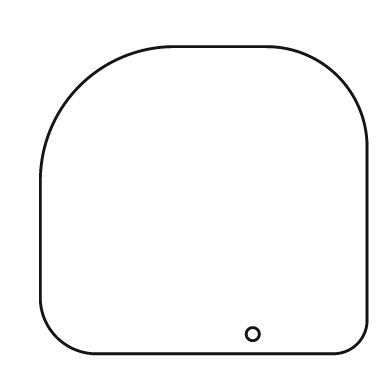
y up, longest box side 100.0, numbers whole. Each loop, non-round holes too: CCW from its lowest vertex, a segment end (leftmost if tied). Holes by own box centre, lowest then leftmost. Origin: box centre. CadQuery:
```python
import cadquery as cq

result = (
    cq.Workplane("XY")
    .moveTo(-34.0, -47.0)
    .lineTo(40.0, -47.0)
    .threePointArc((47.0, -44.0), (50.0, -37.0))
    .lineTo(50.0, 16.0)
    .threePointArc((41.0, 38.0), (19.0, 47.0))
    .lineTo(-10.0, 47.0)
    .threePointArc((-38.0, 35.0), (-50.0, 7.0))
    .lineTo(-50.0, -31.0)
    .threePointArc((-45.0, -42.0), (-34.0, -47.0))
    .close()
    .moveTo(15.0, -41.0)
    .circle(2.0)
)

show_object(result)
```